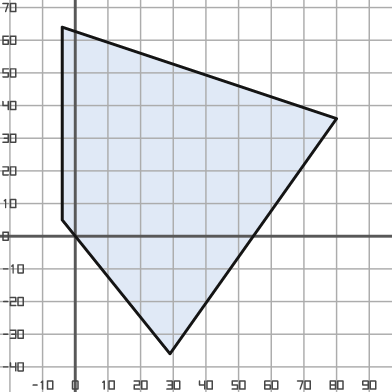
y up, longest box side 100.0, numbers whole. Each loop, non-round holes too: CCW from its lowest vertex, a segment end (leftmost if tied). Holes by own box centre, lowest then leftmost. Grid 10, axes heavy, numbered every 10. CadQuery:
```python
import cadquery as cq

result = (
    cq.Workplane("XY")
    .moveTo(29.0, -36.0)
    .lineTo(80.0, 36.0)
    .lineTo(-4.0, 64.0)
    .lineTo(-4.0, 5.0)
    .close()
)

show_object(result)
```